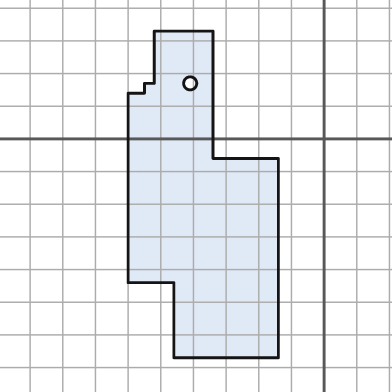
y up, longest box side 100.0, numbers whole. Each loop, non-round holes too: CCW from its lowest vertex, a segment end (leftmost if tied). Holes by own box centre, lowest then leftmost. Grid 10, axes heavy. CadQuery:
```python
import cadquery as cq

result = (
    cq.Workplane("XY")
    .moveTo(-46.0, -67.0)
    .lineTo(-14.0, -67.0)
    .lineTo(-14.0, -6.0)
    .lineTo(-34.0, -6.0)
    .lineTo(-34.0, 33.0)
    .lineTo(-52.0, 33.0)
    .lineTo(-52.0, 17.0)
    .lineTo(-55.0, 17.0)
    .lineTo(-55.0, 14.0)
    .lineTo(-60.0, 14.0)
    .lineTo(-60.0, -44.0)
    .lineTo(-46.0, -44.0)
    .close()
    .moveTo(-41.0, 17.0)
    .circle(2.0)
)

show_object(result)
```